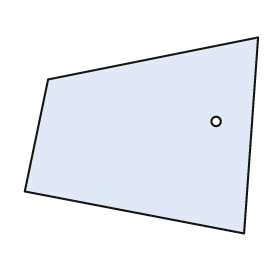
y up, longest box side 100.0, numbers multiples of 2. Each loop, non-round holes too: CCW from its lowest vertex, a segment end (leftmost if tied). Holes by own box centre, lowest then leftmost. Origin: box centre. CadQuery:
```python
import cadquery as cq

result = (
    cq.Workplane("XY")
    .moveTo(44.0, -42.0)
    .lineTo(50.0, 42.0)
    .lineTo(-40.0, 24.0)
    .lineTo(-50.0, -24.0)
    .close()
    .moveTo(32.0, 6.0)
    .circle(2.0)
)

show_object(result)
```